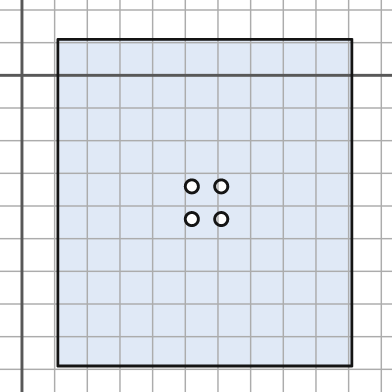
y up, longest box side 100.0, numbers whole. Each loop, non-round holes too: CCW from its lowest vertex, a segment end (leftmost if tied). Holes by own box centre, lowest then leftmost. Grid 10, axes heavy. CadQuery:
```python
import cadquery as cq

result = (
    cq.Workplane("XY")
    .moveTo(11.0, -89.0)
    .lineTo(101.0, -89.0)
    .lineTo(101.0, 11.0)
    .lineTo(11.0, 11.0)
    .close()
    .moveTo(52.0, -44.0)
    .circle(2.0)
    .moveTo(61.0, -44.0)
    .circle(2.0)
    .moveTo(52.0, -34.0)
    .circle(2.0)
    .moveTo(61.0, -34.0)
    .circle(2.0)
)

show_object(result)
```